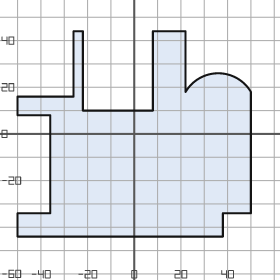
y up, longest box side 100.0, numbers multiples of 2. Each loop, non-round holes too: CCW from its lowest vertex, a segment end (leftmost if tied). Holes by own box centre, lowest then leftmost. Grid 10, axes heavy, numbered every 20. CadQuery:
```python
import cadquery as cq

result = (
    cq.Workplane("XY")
    .moveTo(-50.0, -44.0)
    .lineTo(38.0, -44.0)
    .lineTo(38.0, -34.0)
    .lineTo(50.0, -34.0)
    .lineTo(50.0, 18.0)
    .threePointArc((36.0, 26.0), (22.0, 18.0))
    .lineTo(22.0, 44.0)
    .lineTo(8.0, 44.0)
    .lineTo(8.0, 10.0)
    .lineTo(-22.0, 10.0)
    .lineTo(-22.0, 44.0)
    .lineTo(-26.0, 44.0)
    .lineTo(-26.0, 16.0)
    .lineTo(-50.0, 16.0)
    .lineTo(-50.0, 8.0)
    .lineTo(-36.0, 8.0)
    .lineTo(-36.0, -34.0)
    .lineTo(-50.0, -34.0)
    .close()
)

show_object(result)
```